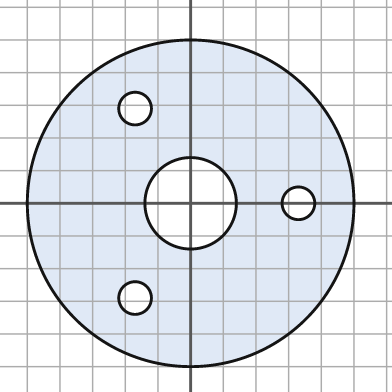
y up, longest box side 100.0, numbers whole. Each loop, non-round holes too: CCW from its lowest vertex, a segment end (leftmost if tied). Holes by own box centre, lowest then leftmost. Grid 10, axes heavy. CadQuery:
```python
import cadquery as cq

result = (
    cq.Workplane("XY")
    .moveTo(0.0, 0.0)
    .circle(50.0)
    .moveTo(-17.0, -29.0)
    .circle(5.0)
    .moveTo(0.0, 0.0)
    .circle(14.0)
    .moveTo(33.0, 0.0)
    .circle(5.0)
    .moveTo(-17.0, 29.0)
    .circle(5.0)
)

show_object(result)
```